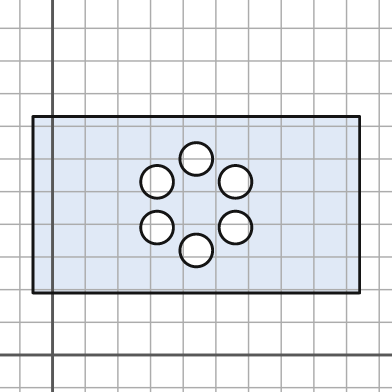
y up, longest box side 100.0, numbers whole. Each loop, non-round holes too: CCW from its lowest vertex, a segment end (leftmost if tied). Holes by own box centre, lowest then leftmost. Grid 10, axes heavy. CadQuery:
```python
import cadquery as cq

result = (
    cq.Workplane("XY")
    .moveTo(-6.0, 19.0)
    .lineTo(94.0, 19.0)
    .lineTo(94.0, 73.0)
    .lineTo(-6.0, 73.0)
    .close()
    .moveTo(44.0, 32.0)
    .circle(5.0)
    .moveTo(32.0, 39.0)
    .circle(5.0)
    .moveTo(56.0, 39.0)
    .circle(5.0)
    .moveTo(32.0, 53.0)
    .circle(5.0)
    .moveTo(56.0, 53.0)
    .circle(5.0)
    .moveTo(44.0, 60.0)
    .circle(5.0)
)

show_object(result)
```